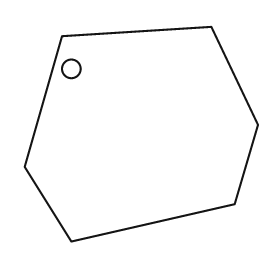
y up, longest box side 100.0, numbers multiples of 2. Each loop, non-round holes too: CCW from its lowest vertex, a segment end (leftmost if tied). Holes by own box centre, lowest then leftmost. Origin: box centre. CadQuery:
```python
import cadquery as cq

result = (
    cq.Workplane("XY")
    .moveTo(-30.0, -46.0)
    .lineTo(40.0, -30.0)
    .lineTo(50.0, 4.0)
    .lineTo(30.0, 46.0)
    .lineTo(-34.0, 42.0)
    .lineTo(-50.0, -14.0)
    .close()
    .moveTo(-30.0, 28.0)
    .circle(4.0)
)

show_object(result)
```